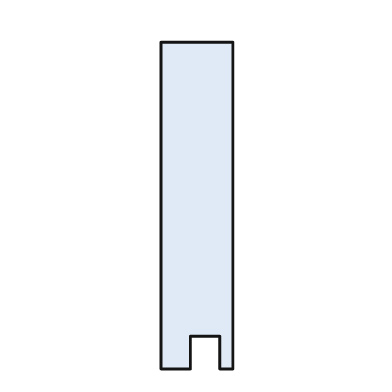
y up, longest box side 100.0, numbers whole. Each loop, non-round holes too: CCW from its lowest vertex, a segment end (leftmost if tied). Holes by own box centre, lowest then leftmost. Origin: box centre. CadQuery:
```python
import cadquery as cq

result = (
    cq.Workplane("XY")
    .moveTo(-11.0, -50.0)
    .lineTo(-2.0, -50.0)
    .lineTo(-2.0, -40.0)
    .lineTo(7.0, -40.0)
    .lineTo(7.0, -50.0)
    .lineTo(11.0, -50.0)
    .lineTo(11.0, 50.0)
    .lineTo(-11.0, 50.0)
    .close()
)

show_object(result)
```